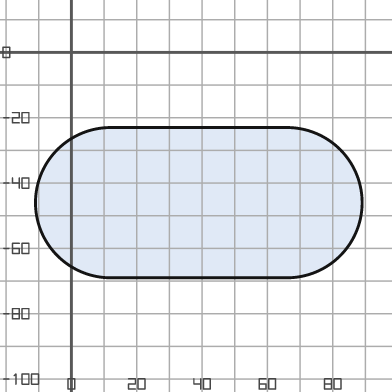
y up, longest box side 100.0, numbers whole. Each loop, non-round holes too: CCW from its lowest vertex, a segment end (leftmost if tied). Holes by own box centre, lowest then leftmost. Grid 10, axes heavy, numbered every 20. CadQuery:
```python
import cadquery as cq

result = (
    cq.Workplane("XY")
    .moveTo(12.0, -69.0)
    .lineTo(66.0, -69.0)
    .threePointArc((89.0, -46.0), (66.0, -23.0))
    .lineTo(12.0, -23.0)
    .threePointArc((-11.0, -46.0), (12.0, -69.0))
    .close()
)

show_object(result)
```